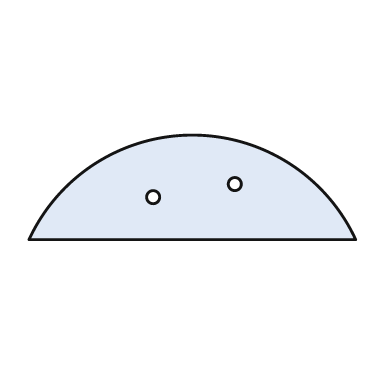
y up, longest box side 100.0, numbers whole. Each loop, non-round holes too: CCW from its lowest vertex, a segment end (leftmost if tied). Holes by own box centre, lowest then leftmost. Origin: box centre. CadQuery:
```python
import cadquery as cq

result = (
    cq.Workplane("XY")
    .moveTo(-50.0, -16.0)
    .lineTo(50.0, -16.0)
    .threePointArc((0.0, 16.0), (-50.0, -16.0))
    .close()
    .moveTo(-12.0, -3.0)
    .circle(2.0)
    .moveTo(13.0, 1.0)
    .circle(2.0)
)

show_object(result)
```